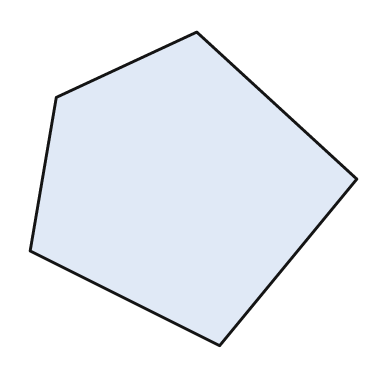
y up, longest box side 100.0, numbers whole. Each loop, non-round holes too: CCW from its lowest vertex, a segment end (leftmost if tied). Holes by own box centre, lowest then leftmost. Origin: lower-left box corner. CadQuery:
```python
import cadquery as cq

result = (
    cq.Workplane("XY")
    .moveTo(58.0, 0.0)
    .lineTo(100.0, 51.0)
    .lineTo(51.0, 96.0)
    .lineTo(8.0, 76.0)
    .lineTo(0.0, 29.0)
    .close()
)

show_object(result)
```